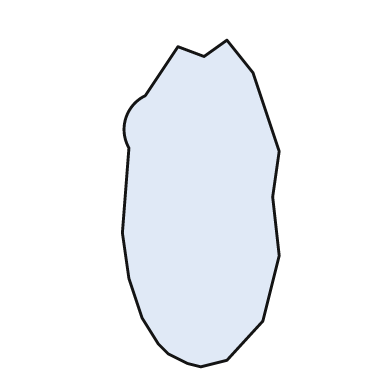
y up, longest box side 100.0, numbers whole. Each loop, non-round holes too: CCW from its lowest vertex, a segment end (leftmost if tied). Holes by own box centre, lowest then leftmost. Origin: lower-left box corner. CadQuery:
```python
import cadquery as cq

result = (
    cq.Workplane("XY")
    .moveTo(24.0, 0.0)
    .lineTo(32.0, 2.0)
    .lineTo(43.0, 14.0)
    .lineTo(48.0, 34.0)
    .lineTo(46.0, 52.0)
    .lineTo(48.0, 66.0)
    .lineTo(40.0, 90.0)
    .lineTo(32.0, 100.0)
    .lineTo(25.0, 95.0)
    .lineTo(17.0, 98.0)
    .lineTo(7.0, 83.0)
    .threePointArc((1.0, 76.0), (2.0, 67.0))
    .lineTo(0.0, 41.0)
    .lineTo(2.0, 27.0)
    .lineTo(6.0, 15.0)
    .lineTo(11.0, 7.0)
    .lineTo(14.0, 4.0)
    .lineTo(20.0, 1.0)
    .close()
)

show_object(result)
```